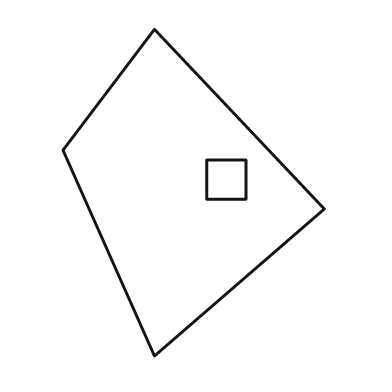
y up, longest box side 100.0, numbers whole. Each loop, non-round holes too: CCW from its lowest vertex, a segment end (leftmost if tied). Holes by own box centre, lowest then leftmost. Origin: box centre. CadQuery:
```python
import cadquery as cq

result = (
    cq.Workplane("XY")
    .moveTo(-12.0, -50.0)
    .lineTo(40.0, -5.0)
    .lineTo(-12.0, 50.0)
    .lineTo(-40.0, 13.0)
    .close()
    .moveTo(4.0, -2.0)
    .lineTo(16.0, -2.0)
    .lineTo(16.0, 10.0)
    .lineTo(4.0, 10.0)
    .close()
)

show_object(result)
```